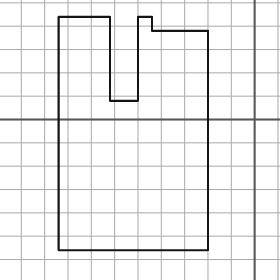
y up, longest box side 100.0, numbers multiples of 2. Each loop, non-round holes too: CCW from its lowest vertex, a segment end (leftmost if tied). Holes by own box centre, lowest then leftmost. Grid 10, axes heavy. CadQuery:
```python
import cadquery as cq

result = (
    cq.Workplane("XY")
    .moveTo(-84.0, -56.0)
    .lineTo(-20.0, -56.0)
    .lineTo(-20.0, 38.0)
    .lineTo(-44.0, 38.0)
    .lineTo(-44.0, 44.0)
    .lineTo(-50.0, 44.0)
    .lineTo(-50.0, 8.0)
    .lineTo(-62.0, 8.0)
    .lineTo(-62.0, 44.0)
    .lineTo(-84.0, 44.0)
    .close()
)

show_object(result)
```